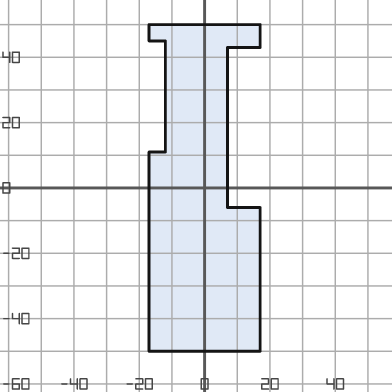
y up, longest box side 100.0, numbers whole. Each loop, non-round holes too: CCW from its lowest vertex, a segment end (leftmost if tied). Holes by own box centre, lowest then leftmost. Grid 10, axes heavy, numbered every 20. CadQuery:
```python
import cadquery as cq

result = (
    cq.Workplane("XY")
    .moveTo(-17.0, -50.0)
    .lineTo(17.0, -50.0)
    .lineTo(17.0, -6.0)
    .lineTo(7.0, -6.0)
    .lineTo(7.0, 43.0)
    .lineTo(17.0, 43.0)
    .lineTo(17.0, 50.0)
    .lineTo(-17.0, 50.0)
    .lineTo(-17.0, 45.0)
    .lineTo(-12.0, 45.0)
    .lineTo(-12.0, 11.0)
    .lineTo(-17.0, 11.0)
    .close()
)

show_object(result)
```